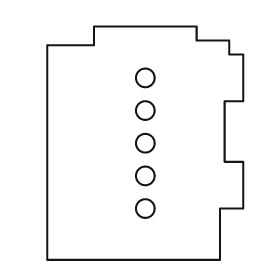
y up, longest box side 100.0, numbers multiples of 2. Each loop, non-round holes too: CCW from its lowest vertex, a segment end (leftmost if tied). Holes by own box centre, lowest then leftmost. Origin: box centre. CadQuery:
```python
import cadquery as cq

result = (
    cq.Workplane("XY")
    .moveTo(-42.0, -50.0)
    .lineTo(32.0, -50.0)
    .lineTo(32.0, -28.0)
    .lineTo(42.0, -28.0)
    .lineTo(42.0, -8.0)
    .lineTo(34.0, -8.0)
    .lineTo(34.0, 18.0)
    .lineTo(42.0, 18.0)
    .lineTo(42.0, 38.0)
    .lineTo(36.0, 38.0)
    .lineTo(36.0, 44.0)
    .lineTo(22.0, 44.0)
    .lineTo(22.0, 50.0)
    .lineTo(-22.0, 50.0)
    .lineTo(-22.0, 42.0)
    .lineTo(-42.0, 42.0)
    .close()
    .moveTo(0.0, -28.0)
    .circle(4.0)
    .moveTo(0.0, -14.0)
    .circle(4.0)
    .moveTo(0.0, 0.0)
    .circle(4.0)
    .moveTo(0.0, 14.0)
    .circle(4.0)
    .moveTo(0.0, 28.0)
    .circle(4.0)
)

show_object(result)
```